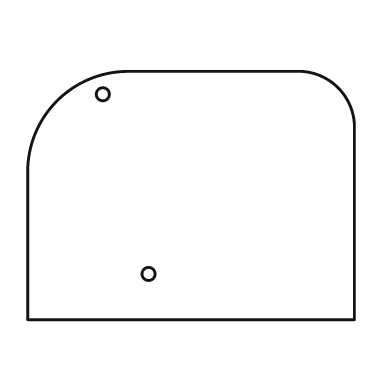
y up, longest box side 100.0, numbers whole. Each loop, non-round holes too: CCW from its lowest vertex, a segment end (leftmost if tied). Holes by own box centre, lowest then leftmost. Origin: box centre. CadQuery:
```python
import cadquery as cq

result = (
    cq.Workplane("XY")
    .moveTo(-50.0, -38.0)
    .lineTo(50.0, -38.0)
    .lineTo(50.0, 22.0)
    .threePointArc((45.0, 33.0), (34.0, 38.0))
    .lineTo(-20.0, 38.0)
    .threePointArc((-41.0, 29.0), (-50.0, 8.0))
    .close()
    .moveTo(-13.0, -24.0)
    .circle(2.0)
    .moveTo(-27.0, 31.0)
    .circle(2.0)
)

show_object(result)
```